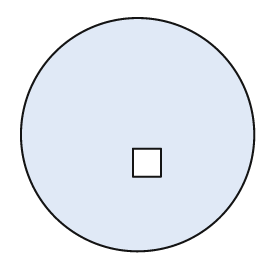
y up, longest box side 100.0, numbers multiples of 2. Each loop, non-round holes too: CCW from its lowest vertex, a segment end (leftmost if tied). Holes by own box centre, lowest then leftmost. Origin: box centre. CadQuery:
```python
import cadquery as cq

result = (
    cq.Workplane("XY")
    .moveTo(0.0, 0.0)
    .circle(50.0)
    .moveTo(-2.0, -18.0)
    .lineTo(10.0, -18.0)
    .lineTo(10.0, -6.0)
    .lineTo(-2.0, -6.0)
    .close()
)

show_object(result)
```